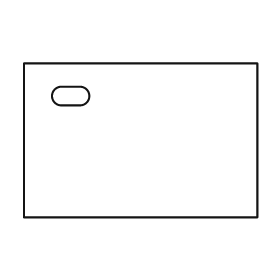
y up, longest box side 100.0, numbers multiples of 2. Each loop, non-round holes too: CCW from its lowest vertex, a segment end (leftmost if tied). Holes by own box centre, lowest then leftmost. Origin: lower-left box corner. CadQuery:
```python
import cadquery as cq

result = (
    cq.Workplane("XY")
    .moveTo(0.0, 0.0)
    .lineTo(100.0, 0.0)
    .lineTo(100.0, 66.0)
    .lineTo(0.0, 66.0)
    .close()
    .moveTo(16.0, 48.0)
    .lineTo(24.0, 48.0)
    .threePointArc((28.0, 52.0), (24.0, 56.0))
    .lineTo(16.0, 56.0)
    .threePointArc((12.0, 52.0), (16.0, 48.0))
    .close()
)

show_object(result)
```